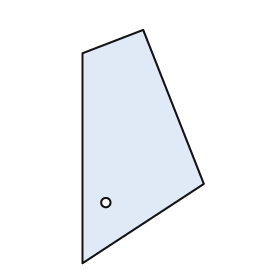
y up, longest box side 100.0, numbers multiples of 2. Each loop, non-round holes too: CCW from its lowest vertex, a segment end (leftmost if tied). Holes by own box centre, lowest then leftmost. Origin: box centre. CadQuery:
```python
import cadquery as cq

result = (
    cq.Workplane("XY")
    .moveTo(-26.0, -50.0)
    .lineTo(26.0, -16.0)
    .lineTo(0.0, 50.0)
    .lineTo(-26.0, 40.0)
    .close()
    .moveTo(-16.0, -24.0)
    .circle(2.0)
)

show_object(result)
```